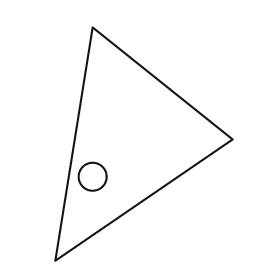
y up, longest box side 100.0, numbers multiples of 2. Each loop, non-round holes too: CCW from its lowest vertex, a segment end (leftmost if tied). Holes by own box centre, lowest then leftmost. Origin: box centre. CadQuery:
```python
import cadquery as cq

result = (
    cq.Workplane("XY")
    .moveTo(-38.0, -50.0)
    .lineTo(38.0, 2.0)
    .lineTo(-22.0, 50.0)
    .close()
    .moveTo(-22.0, -14.0)
    .circle(6.0)
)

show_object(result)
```